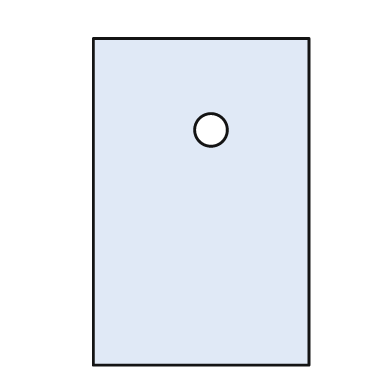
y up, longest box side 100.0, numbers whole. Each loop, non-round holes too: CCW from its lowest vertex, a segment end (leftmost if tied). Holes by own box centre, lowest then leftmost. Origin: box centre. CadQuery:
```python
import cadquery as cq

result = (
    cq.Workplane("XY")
    .moveTo(-33.0, -50.0)
    .lineTo(33.0, -50.0)
    .lineTo(33.0, 50.0)
    .lineTo(-33.0, 50.0)
    .close()
    .moveTo(3.0, 22.0)
    .circle(5.0)
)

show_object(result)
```